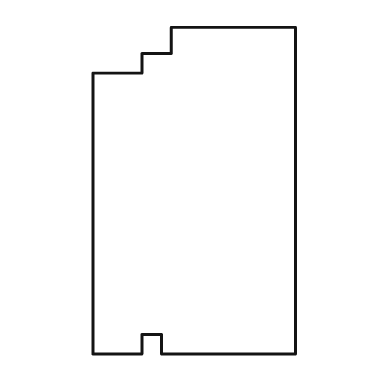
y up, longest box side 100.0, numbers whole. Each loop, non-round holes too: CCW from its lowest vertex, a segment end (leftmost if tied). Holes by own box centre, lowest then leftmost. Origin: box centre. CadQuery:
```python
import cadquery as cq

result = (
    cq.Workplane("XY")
    .moveTo(-31.0, -50.0)
    .lineTo(-16.0, -50.0)
    .lineTo(-16.0, -44.0)
    .lineTo(-10.0, -44.0)
    .lineTo(-10.0, -50.0)
    .lineTo(31.0, -50.0)
    .lineTo(31.0, 50.0)
    .lineTo(-7.0, 50.0)
    .lineTo(-7.0, 42.0)
    .lineTo(-16.0, 42.0)
    .lineTo(-16.0, 36.0)
    .lineTo(-31.0, 36.0)
    .close()
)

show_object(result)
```